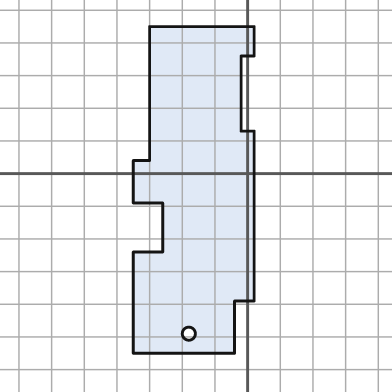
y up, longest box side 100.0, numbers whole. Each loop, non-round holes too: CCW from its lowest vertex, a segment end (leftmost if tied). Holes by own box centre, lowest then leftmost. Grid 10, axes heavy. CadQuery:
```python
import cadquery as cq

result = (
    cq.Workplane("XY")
    .moveTo(-35.0, -55.0)
    .lineTo(-4.0, -55.0)
    .lineTo(-4.0, -39.0)
    .lineTo(2.0, -39.0)
    .lineTo(2.0, 13.0)
    .lineTo(-2.0, 13.0)
    .lineTo(-2.0, 36.0)
    .lineTo(2.0, 36.0)
    .lineTo(2.0, 45.0)
    .lineTo(-30.0, 45.0)
    .lineTo(-30.0, 4.0)
    .lineTo(-35.0, 4.0)
    .lineTo(-35.0, -9.0)
    .lineTo(-26.0, -9.0)
    .lineTo(-26.0, -24.0)
    .lineTo(-35.0, -24.0)
    .close()
    .moveTo(-18.0, -49.0)
    .circle(2.0)
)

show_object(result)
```